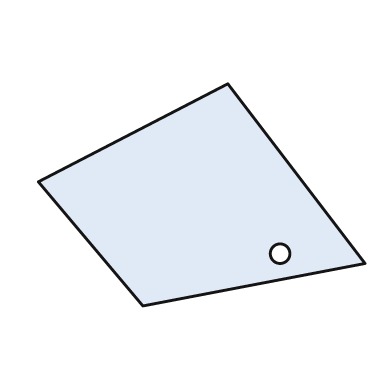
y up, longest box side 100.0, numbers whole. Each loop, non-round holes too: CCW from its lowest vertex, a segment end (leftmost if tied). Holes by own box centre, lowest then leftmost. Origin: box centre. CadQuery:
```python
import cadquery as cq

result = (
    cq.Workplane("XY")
    .moveTo(-18.0, -34.0)
    .lineTo(50.0, -21.0)
    .lineTo(8.0, 34.0)
    .lineTo(-50.0, 4.0)
    .close()
    .moveTo(24.0, -18.0)
    .circle(3.0)
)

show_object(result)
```